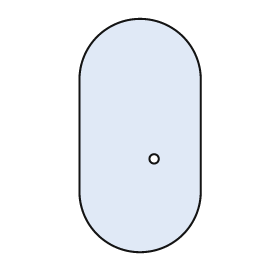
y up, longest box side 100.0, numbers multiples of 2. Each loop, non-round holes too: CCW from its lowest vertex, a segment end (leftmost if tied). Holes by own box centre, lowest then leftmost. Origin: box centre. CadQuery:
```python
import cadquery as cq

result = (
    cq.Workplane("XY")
    .moveTo(-26.0, -24.0)
    .threePointArc((0.0, -50.0), (26.0, -24.0))
    .lineTo(26.0, 24.0)
    .threePointArc((0.0, 50.0), (-26.0, 24.0))
    .close()
    .moveTo(6.0, -10.0)
    .circle(2.0)
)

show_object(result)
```